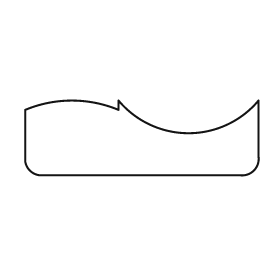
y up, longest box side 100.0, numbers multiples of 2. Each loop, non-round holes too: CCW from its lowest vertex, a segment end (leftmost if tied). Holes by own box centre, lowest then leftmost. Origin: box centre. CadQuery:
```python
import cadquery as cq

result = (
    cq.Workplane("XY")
    .moveTo(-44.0, -16.0)
    .lineTo(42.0, -16.0)
    .threePointArc((48.0, -14.0), (50.0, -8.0))
    .lineTo(50.0, 16.0)
    .threePointArc((20.0, 2.0), (-10.0, 16.0))
    .lineTo(-10.0, 12.0)
    .threePointArc((-30.0, 16.0), (-50.0, 12.0))
    .lineTo(-50.0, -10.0)
    .threePointArc((-48.0, -14.0), (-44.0, -16.0))
    .close()
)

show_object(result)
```